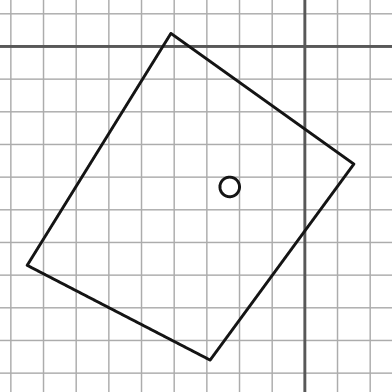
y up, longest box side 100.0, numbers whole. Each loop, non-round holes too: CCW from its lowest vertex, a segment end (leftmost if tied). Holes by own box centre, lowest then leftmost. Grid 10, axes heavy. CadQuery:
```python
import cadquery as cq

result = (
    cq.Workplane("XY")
    .moveTo(-29.0, -96.0)
    .lineTo(15.0, -36.0)
    .lineTo(-41.0, 4.0)
    .lineTo(-85.0, -67.0)
    .close()
    .moveTo(-23.0, -43.0)
    .circle(3.0)
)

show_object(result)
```